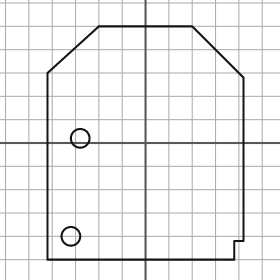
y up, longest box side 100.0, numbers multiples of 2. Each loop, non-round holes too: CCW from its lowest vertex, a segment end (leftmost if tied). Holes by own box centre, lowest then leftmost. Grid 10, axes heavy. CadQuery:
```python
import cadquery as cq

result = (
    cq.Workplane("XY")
    .moveTo(-42.0, -50.0)
    .lineTo(38.0, -50.0)
    .lineTo(38.0, -42.0)
    .lineTo(42.0, -42.0)
    .lineTo(42.0, 28.0)
    .lineTo(20.0, 50.0)
    .lineTo(-20.0, 50.0)
    .lineTo(-42.0, 30.0)
    .close()
    .moveTo(-32.0, -40.0)
    .circle(4.0)
    .moveTo(-28.0, 2.0)
    .circle(4.0)
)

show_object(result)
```